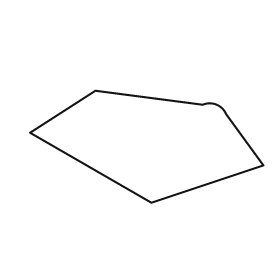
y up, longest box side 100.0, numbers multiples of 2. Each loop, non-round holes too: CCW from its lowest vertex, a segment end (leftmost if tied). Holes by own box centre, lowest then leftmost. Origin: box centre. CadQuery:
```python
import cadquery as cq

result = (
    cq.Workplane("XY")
    .moveTo(2.0, -24.0)
    .lineTo(50.0, -8.0)
    .lineTo(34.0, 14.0)
    .threePointArc((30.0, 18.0), (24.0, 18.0))
    .lineTo(-22.0, 24.0)
    .lineTo(-50.0, 6.0)
    .close()
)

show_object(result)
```